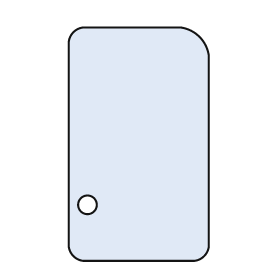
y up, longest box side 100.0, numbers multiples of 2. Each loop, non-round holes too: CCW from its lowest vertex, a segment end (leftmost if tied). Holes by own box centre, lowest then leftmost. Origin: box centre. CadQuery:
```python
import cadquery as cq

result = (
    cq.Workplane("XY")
    .moveTo(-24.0, -50.0)
    .lineTo(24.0, -50.0)
    .threePointArc((28.0, -48.0), (30.0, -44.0))
    .lineTo(30.0, 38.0)
    .threePointArc((26.0, 46.0), (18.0, 50.0))
    .lineTo(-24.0, 50.0)
    .threePointArc((-28.0, 48.0), (-30.0, 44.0))
    .lineTo(-30.0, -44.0)
    .threePointArc((-28.0, -48.0), (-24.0, -50.0))
    .close()
    .moveTo(-22.0, -26.0)
    .circle(4.0)
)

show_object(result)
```